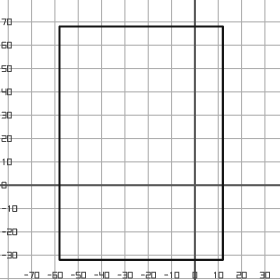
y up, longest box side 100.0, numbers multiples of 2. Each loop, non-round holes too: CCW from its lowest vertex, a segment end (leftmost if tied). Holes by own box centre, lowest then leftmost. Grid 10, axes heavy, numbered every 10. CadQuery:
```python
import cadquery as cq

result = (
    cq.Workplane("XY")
    .moveTo(-58.0, -32.0)
    .lineTo(12.0, -32.0)
    .lineTo(12.0, 68.0)
    .lineTo(-58.0, 68.0)
    .close()
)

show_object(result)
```